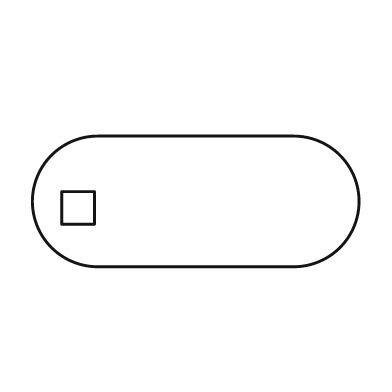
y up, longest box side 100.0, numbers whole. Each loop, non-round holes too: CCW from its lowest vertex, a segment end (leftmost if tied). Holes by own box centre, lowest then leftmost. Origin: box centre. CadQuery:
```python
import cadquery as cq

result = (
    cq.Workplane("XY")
    .moveTo(-30.0, -20.0)
    .lineTo(30.0, -20.0)
    .threePointArc((50.0, 0.0), (30.0, 20.0))
    .lineTo(-30.0, 20.0)
    .threePointArc((-50.0, 0.0), (-30.0, -20.0))
    .close()
    .moveTo(-41.0, -7.0)
    .lineTo(-31.0, -7.0)
    .lineTo(-31.0, 3.0)
    .lineTo(-41.0, 3.0)
    .close()
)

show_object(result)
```